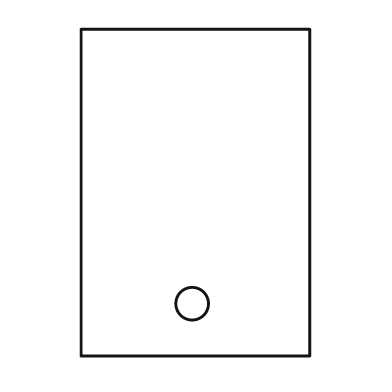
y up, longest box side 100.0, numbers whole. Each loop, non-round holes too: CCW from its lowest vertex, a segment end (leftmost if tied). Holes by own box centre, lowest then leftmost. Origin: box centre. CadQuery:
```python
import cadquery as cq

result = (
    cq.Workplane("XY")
    .moveTo(-35.0, -50.0)
    .lineTo(35.0, -50.0)
    .lineTo(35.0, 50.0)
    .lineTo(-35.0, 50.0)
    .close()
    .moveTo(-1.0, -34.0)
    .circle(5.0)
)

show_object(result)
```